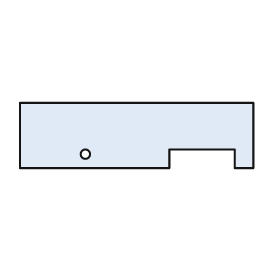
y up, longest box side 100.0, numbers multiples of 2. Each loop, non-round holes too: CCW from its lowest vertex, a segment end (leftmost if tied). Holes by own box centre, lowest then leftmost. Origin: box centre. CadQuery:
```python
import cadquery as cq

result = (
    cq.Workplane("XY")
    .moveTo(-50.0, -14.0)
    .lineTo(14.0, -14.0)
    .lineTo(14.0, -6.0)
    .lineTo(42.0, -6.0)
    .lineTo(42.0, -14.0)
    .lineTo(50.0, -14.0)
    .lineTo(50.0, 14.0)
    .lineTo(-50.0, 14.0)
    .close()
    .moveTo(-22.0, -8.0)
    .circle(2.0)
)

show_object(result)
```